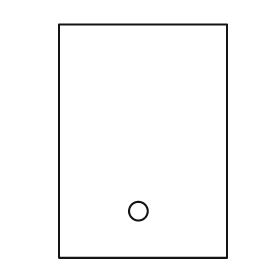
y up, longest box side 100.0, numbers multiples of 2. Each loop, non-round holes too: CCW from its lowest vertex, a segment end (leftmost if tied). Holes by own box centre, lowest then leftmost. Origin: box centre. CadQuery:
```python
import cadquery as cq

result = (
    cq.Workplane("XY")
    .moveTo(-36.0, -50.0)
    .lineTo(36.0, -50.0)
    .lineTo(36.0, 50.0)
    .lineTo(-36.0, 50.0)
    .close()
    .moveTo(-2.0, -30.0)
    .circle(4.0)
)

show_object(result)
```